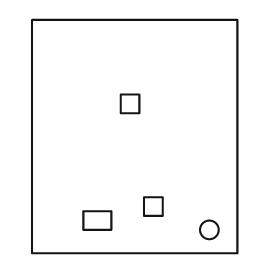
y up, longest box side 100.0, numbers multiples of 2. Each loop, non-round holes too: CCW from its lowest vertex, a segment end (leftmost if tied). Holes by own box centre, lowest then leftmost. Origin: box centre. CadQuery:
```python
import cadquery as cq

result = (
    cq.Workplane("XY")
    .moveTo(-44.0, -50.0)
    .lineTo(44.0, -50.0)
    .lineTo(44.0, 50.0)
    .lineTo(-44.0, 50.0)
    .close()
    .moveTo(32.0, -40.0)
    .circle(4.0)
    .moveTo(-22.0, -40.0)
    .lineTo(-10.0, -40.0)
    .lineTo(-10.0, -32.0)
    .lineTo(-22.0, -32.0)
    .close()
    .moveTo(4.0, -34.0)
    .lineTo(12.0, -34.0)
    .lineTo(12.0, -26.0)
    .lineTo(4.0, -26.0)
    .close()
    .moveTo(-6.0, 10.0)
    .lineTo(2.0, 10.0)
    .lineTo(2.0, 18.0)
    .lineTo(-6.0, 18.0)
    .close()
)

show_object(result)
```